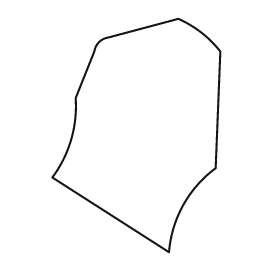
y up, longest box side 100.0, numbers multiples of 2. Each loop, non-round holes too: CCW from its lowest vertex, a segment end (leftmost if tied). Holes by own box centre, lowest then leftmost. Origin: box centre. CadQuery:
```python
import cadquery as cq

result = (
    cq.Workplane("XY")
    .moveTo(14.0, -50.0)
    .threePointArc((20.0, -30.0), (34.0, -14.0))
    .lineTo(36.0, 36.0)
    .threePointArc((28.0, 44.0), (18.0, 50.0))
    .lineTo(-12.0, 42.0)
    .threePointArc((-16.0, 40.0), (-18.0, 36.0))
    .lineTo(-26.0, 16.0)
    .threePointArc((-28.0, -2.0), (-36.0, -18.0))
    .close()
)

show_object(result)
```